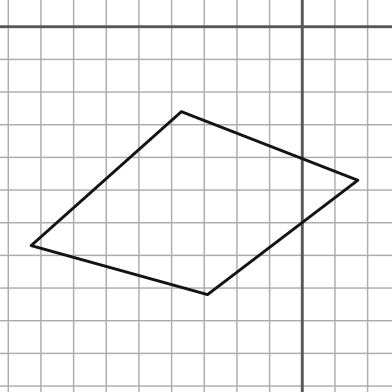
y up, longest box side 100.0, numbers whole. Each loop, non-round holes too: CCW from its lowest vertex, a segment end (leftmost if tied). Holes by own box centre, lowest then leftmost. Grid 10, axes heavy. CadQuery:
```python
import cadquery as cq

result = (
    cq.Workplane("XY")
    .moveTo(-29.0, -82.0)
    .lineTo(17.0, -47.0)
    .lineTo(-37.0, -26.0)
    .lineTo(-83.0, -67.0)
    .close()
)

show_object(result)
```